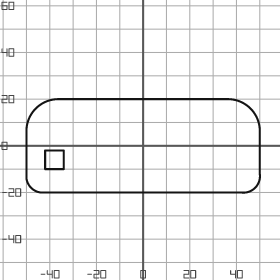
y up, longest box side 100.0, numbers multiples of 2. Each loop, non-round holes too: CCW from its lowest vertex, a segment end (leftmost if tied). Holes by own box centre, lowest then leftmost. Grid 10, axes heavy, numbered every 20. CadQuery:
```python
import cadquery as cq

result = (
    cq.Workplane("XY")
    .moveTo(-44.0, -20.0)
    .lineTo(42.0, -20.0)
    .threePointArc((48.0, -18.0), (50.0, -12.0))
    .lineTo(50.0, 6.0)
    .threePointArc((46.0, 16.0), (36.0, 20.0))
    .lineTo(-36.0, 20.0)
    .threePointArc((-46.0, 16.0), (-50.0, 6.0))
    .lineTo(-50.0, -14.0)
    .threePointArc((-48.0, -18.0), (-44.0, -20.0))
    .close()
    .moveTo(-42.0, -10.0)
    .lineTo(-34.0, -10.0)
    .lineTo(-34.0, -2.0)
    .lineTo(-42.0, -2.0)
    .close()
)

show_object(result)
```